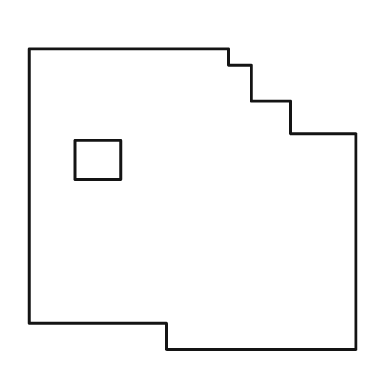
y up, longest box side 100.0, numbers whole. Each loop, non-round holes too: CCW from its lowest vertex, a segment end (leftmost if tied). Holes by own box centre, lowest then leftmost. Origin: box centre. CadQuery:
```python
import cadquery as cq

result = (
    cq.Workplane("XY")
    .moveTo(-8.0, -46.0)
    .lineTo(50.0, -46.0)
    .lineTo(50.0, 20.0)
    .lineTo(30.0, 20.0)
    .lineTo(30.0, 30.0)
    .lineTo(18.0, 30.0)
    .lineTo(18.0, 41.0)
    .lineTo(11.0, 41.0)
    .lineTo(11.0, 46.0)
    .lineTo(-50.0, 46.0)
    .lineTo(-50.0, -38.0)
    .lineTo(-8.0, -38.0)
    .close()
    .moveTo(-36.0, 6.0)
    .lineTo(-22.0, 6.0)
    .lineTo(-22.0, 18.0)
    .lineTo(-36.0, 18.0)
    .close()
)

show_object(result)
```